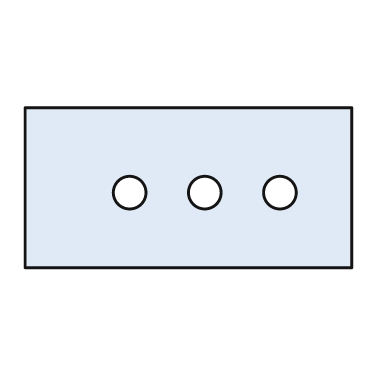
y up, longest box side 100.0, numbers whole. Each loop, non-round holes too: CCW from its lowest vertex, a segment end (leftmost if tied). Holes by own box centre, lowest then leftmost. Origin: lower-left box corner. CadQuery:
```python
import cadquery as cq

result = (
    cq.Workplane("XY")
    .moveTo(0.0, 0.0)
    .lineTo(100.0, 0.0)
    .lineTo(100.0, 49.0)
    .lineTo(0.0, 49.0)
    .close()
    .moveTo(32.0, 23.0)
    .circle(5.0)
    .moveTo(55.0, 23.0)
    .circle(5.0)
    .moveTo(78.0, 23.0)
    .circle(5.0)
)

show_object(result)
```